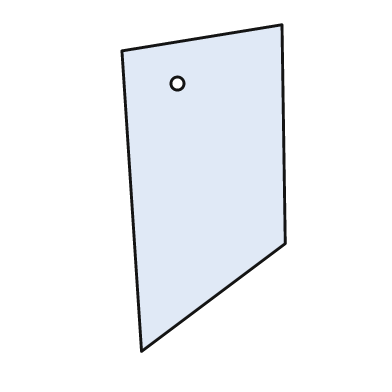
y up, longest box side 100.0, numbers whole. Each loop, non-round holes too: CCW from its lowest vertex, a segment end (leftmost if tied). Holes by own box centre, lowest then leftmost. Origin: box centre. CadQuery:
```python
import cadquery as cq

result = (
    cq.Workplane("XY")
    .moveTo(-19.0, -50.0)
    .lineTo(25.0, -17.0)
    .lineTo(24.0, 50.0)
    .lineTo(-25.0, 42.0)
    .close()
    .moveTo(-8.0, 32.0)
    .circle(2.0)
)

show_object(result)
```